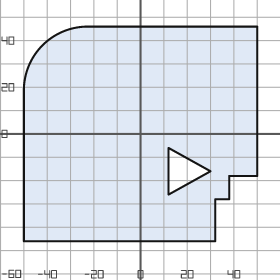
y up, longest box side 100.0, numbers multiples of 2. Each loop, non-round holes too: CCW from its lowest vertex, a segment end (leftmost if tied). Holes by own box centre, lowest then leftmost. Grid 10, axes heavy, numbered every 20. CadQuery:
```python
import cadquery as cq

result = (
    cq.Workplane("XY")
    .moveTo(-50.0, -46.0)
    .lineTo(32.0, -46.0)
    .lineTo(32.0, -28.0)
    .lineTo(38.0, -28.0)
    .lineTo(38.0, -18.0)
    .lineTo(50.0, -18.0)
    .lineTo(50.0, 46.0)
    .lineTo(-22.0, 46.0)
    .threePointArc((-42.0, 38.0), (-50.0, 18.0))
    .close()
    .moveTo(12.0, -26.0)
    .lineTo(30.0, -16.0)
    .lineTo(12.0, -6.0)
    .close()
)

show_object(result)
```